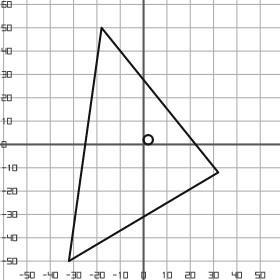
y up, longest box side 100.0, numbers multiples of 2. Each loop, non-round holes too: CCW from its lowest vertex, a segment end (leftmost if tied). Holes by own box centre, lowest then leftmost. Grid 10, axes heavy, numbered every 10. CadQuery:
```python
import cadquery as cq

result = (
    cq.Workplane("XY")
    .moveTo(-32.0, -50.0)
    .lineTo(32.0, -12.0)
    .lineTo(-18.0, 50.0)
    .close()
    .moveTo(2.0, 2.0)
    .circle(2.0)
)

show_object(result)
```